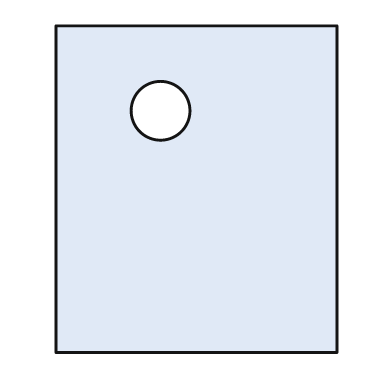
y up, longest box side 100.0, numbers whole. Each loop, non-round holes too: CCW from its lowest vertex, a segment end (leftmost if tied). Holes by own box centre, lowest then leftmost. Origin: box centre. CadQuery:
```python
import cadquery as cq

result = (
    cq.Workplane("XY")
    .moveTo(-43.0, -50.0)
    .lineTo(43.0, -50.0)
    .lineTo(43.0, 50.0)
    .lineTo(-43.0, 50.0)
    .close()
    .moveTo(-11.0, 24.0)
    .circle(9.0)
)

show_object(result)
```